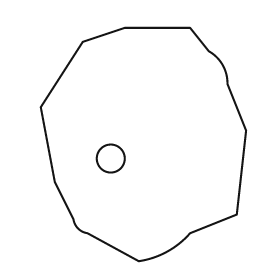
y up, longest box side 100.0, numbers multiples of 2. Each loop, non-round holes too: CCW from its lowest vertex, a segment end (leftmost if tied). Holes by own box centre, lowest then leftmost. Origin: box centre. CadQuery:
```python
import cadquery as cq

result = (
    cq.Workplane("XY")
    .moveTo(-2.0, -50.0)
    .threePointArc((10.0, -46.0), (20.0, -38.0))
    .lineTo(40.0, -30.0)
    .lineTo(44.0, 6.0)
    .lineTo(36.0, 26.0)
    .threePointArc((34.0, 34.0), (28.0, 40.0))
    .lineTo(20.0, 50.0)
    .lineTo(-8.0, 50.0)
    .lineTo(-26.0, 44.0)
    .lineTo(-44.0, 16.0)
    .lineTo(-38.0, -16.0)
    .lineTo(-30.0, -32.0)
    .threePointArc((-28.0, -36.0), (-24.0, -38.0))
    .close()
    .moveTo(-14.0, -6.0)
    .circle(6.0)
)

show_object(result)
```